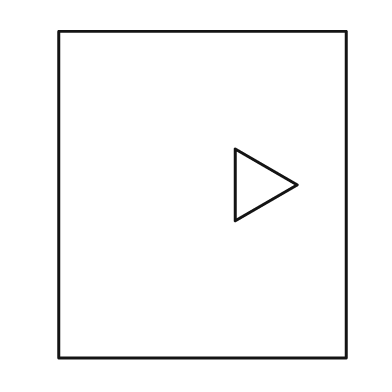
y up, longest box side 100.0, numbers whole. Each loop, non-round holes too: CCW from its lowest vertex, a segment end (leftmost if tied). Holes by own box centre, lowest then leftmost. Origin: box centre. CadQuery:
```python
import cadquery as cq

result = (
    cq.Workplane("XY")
    .moveTo(-44.0, -50.0)
    .lineTo(44.0, -50.0)
    .lineTo(44.0, 50.0)
    .lineTo(-44.0, 50.0)
    .close()
    .moveTo(10.0, -8.0)
    .lineTo(29.0, 3.0)
    .lineTo(10.0, 14.0)
    .close()
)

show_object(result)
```